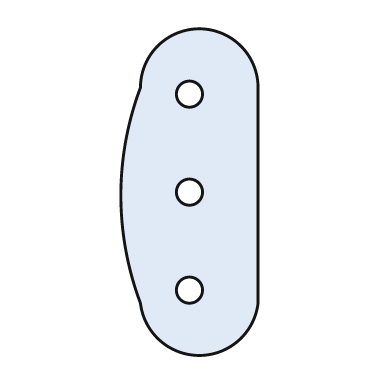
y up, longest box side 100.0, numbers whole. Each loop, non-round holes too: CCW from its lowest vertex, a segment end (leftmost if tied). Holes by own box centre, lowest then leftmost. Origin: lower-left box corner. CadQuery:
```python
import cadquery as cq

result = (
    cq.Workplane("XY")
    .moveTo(6.0, 16.0)
    .threePointArc((24.0, 0.0), (42.0, 16.0))
    .lineTo(42.0, 82.0)
    .threePointArc((24.0, 100.0), (6.0, 82.0))
    .threePointArc((0.0, 49.0), (6.0, 16.0))
    .close()
    .moveTo(21.0, 20.0)
    .circle(4.0)
    .moveTo(21.0, 50.0)
    .circle(4.0)
    .moveTo(21.0, 80.0)
    .circle(4.0)
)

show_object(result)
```